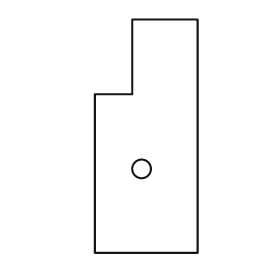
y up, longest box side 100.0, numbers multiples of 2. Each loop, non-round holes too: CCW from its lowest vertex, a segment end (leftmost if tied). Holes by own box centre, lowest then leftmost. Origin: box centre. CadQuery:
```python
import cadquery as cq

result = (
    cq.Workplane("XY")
    .moveTo(-22.0, -50.0)
    .lineTo(22.0, -50.0)
    .lineTo(22.0, 50.0)
    .lineTo(-6.0, 50.0)
    .lineTo(-6.0, 18.0)
    .lineTo(-22.0, 18.0)
    .close()
    .moveTo(-2.0, -14.0)
    .circle(4.0)
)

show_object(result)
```